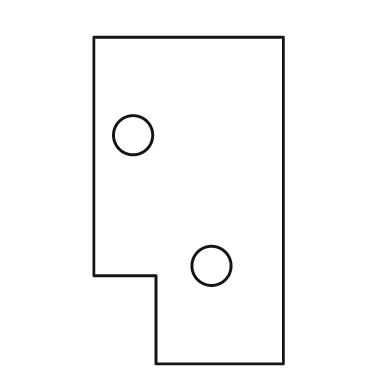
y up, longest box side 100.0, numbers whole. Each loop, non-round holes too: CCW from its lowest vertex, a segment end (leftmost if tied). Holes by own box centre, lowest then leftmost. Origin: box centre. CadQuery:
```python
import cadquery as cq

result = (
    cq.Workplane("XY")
    .moveTo(-10.0, -50.0)
    .lineTo(29.0, -50.0)
    .lineTo(29.0, 50.0)
    .lineTo(-29.0, 50.0)
    .lineTo(-29.0, -23.0)
    .lineTo(-10.0, -23.0)
    .close()
    .moveTo(7.0, -20.0)
    .circle(6.0)
    .moveTo(-17.0, 20.0)
    .circle(6.0)
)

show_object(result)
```